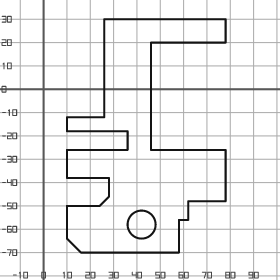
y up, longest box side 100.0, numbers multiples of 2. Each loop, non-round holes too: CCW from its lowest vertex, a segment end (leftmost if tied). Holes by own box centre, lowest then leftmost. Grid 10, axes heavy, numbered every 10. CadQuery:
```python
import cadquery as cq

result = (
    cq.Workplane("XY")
    .moveTo(16.0, -70.0)
    .lineTo(58.0, -70.0)
    .lineTo(58.0, -56.0)
    .lineTo(62.0, -56.0)
    .lineTo(62.0, -48.0)
    .lineTo(78.0, -48.0)
    .lineTo(78.0, -26.0)
    .lineTo(46.0, -26.0)
    .lineTo(46.0, 20.0)
    .lineTo(78.0, 20.0)
    .lineTo(78.0, 30.0)
    .lineTo(26.0, 30.0)
    .lineTo(26.0, -12.0)
    .lineTo(10.0, -12.0)
    .lineTo(10.0, -18.0)
    .lineTo(36.0, -18.0)
    .lineTo(36.0, -26.0)
    .lineTo(10.0, -26.0)
    .lineTo(10.0, -38.0)
    .lineTo(28.0, -38.0)
    .lineTo(28.0, -46.0)
    .lineTo(24.0, -50.0)
    .lineTo(10.0, -50.0)
    .lineTo(10.0, -64.0)
    .close()
    .moveTo(42.0, -58.0)
    .circle(6.0)
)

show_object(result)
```